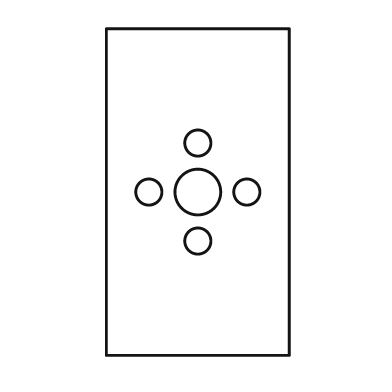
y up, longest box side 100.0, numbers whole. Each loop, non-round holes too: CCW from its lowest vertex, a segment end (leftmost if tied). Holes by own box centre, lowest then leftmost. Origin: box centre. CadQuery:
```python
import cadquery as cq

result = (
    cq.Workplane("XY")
    .moveTo(-28.0, -50.0)
    .lineTo(28.0, -50.0)
    .lineTo(28.0, 50.0)
    .lineTo(-28.0, 50.0)
    .close()
    .moveTo(0.0, -15.0)
    .circle(4.0)
    .moveTo(-15.0, 0.0)
    .circle(4.0)
    .moveTo(0.0, 0.0)
    .circle(7.0)
    .moveTo(15.0, 0.0)
    .circle(4.0)
    .moveTo(0.0, 15.0)
    .circle(4.0)
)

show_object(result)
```